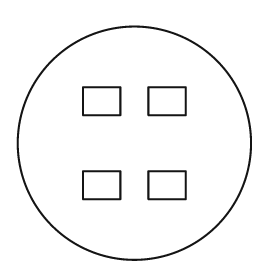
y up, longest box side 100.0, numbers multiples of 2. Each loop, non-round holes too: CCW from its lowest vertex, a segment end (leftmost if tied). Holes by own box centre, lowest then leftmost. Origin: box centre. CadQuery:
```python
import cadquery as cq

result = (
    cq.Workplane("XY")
    .moveTo(0.0, 0.0)
    .circle(50.0)
    .moveTo(-22.0, -24.0)
    .lineTo(-6.0, -24.0)
    .lineTo(-6.0, -12.0)
    .lineTo(-22.0, -12.0)
    .close()
    .moveTo(6.0, -24.0)
    .lineTo(22.0, -24.0)
    .lineTo(22.0, -12.0)
    .lineTo(6.0, -12.0)
    .close()
    .moveTo(-22.0, 12.0)
    .lineTo(-6.0, 12.0)
    .lineTo(-6.0, 24.0)
    .lineTo(-22.0, 24.0)
    .close()
    .moveTo(6.0, 12.0)
    .lineTo(22.0, 12.0)
    .lineTo(22.0, 24.0)
    .lineTo(6.0, 24.0)
    .close()
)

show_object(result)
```